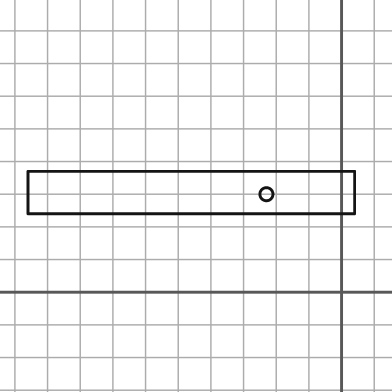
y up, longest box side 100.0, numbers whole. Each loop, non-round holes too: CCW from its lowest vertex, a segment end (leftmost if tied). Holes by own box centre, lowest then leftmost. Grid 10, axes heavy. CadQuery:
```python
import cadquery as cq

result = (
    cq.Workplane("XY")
    .moveTo(-96.0, 24.0)
    .lineTo(4.0, 24.0)
    .lineTo(4.0, 37.0)
    .lineTo(-96.0, 37.0)
    .close()
    .moveTo(-23.0, 30.0)
    .circle(2.0)
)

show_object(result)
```